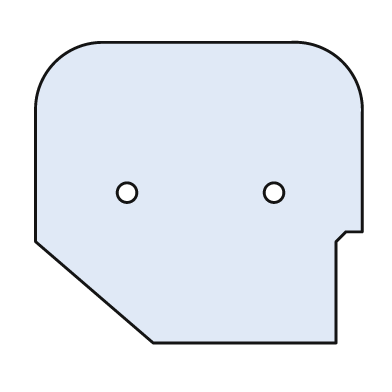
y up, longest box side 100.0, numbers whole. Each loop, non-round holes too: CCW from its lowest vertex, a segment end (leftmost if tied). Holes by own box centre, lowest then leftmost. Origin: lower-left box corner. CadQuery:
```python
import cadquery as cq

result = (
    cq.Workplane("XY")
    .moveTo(36.0, 0.0)
    .lineTo(92.0, 0.0)
    .lineTo(92.0, 31.0)
    .lineTo(95.0, 34.0)
    .lineTo(100.0, 34.0)
    .lineTo(100.0, 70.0)
    .threePointArc((94.0, 86.0), (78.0, 92.0))
    .lineTo(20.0, 92.0)
    .threePointArc((6.0, 86.0), (0.0, 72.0))
    .lineTo(0.0, 31.0)
    .close()
    .moveTo(28.0, 46.0)
    .circle(3.0)
    .moveTo(73.0, 46.0)
    .circle(3.0)
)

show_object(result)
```